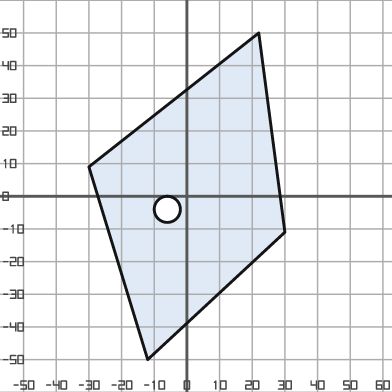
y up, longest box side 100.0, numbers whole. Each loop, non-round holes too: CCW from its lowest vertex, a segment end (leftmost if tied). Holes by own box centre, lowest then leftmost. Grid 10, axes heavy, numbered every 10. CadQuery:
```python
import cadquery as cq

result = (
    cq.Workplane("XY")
    .moveTo(-12.0, -50.0)
    .lineTo(30.0, -11.0)
    .lineTo(22.0, 50.0)
    .lineTo(-30.0, 9.0)
    .close()
    .moveTo(-6.0, -4.0)
    .circle(4.0)
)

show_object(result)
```